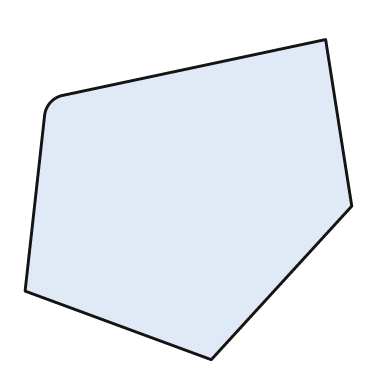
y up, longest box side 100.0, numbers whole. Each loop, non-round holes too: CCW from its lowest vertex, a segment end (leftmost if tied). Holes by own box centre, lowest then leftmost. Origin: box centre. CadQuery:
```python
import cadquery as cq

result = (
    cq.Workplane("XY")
    .moveTo(7.0, -49.0)
    .lineTo(50.0, -2.0)
    .lineTo(42.0, 49.0)
    .lineTo(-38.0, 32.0)
    .threePointArc((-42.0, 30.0), (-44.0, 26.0))
    .lineTo(-50.0, -28.0)
    .close()
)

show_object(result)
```